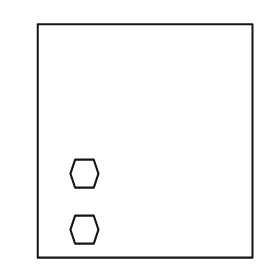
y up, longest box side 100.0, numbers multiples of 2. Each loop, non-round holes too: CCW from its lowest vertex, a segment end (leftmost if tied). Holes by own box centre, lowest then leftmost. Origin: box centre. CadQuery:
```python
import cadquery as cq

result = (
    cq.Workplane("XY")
    .moveTo(-46.0, -50.0)
    .lineTo(46.0, -50.0)
    .lineTo(46.0, 50.0)
    .lineTo(-46.0, 50.0)
    .close()
    .moveTo(-30.0, -44.0)
    .lineTo(-22.0, -44.0)
    .lineTo(-20.0, -38.0)
    .lineTo(-22.0, -32.0)
    .lineTo(-30.0, -32.0)
    .lineTo(-32.0, -38.0)
    .close()
    .moveTo(-30.0, -20.0)
    .lineTo(-22.0, -20.0)
    .lineTo(-20.0, -14.0)
    .lineTo(-22.0, -8.0)
    .lineTo(-30.0, -8.0)
    .lineTo(-32.0, -14.0)
    .close()
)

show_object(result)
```